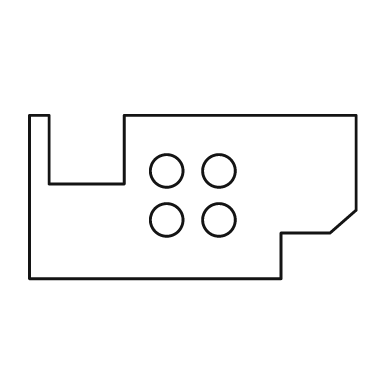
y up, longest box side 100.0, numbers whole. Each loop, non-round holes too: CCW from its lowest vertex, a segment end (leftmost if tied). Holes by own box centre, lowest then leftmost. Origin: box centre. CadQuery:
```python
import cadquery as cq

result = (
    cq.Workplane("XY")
    .moveTo(-50.0, -25.0)
    .lineTo(27.0, -25.0)
    .lineTo(27.0, -11.0)
    .lineTo(42.0, -11.0)
    .lineTo(50.0, -4.0)
    .lineTo(50.0, 25.0)
    .lineTo(-21.0, 25.0)
    .lineTo(-21.0, 4.0)
    .lineTo(-44.0, 4.0)
    .lineTo(-44.0, 25.0)
    .lineTo(-50.0, 25.0)
    .close()
    .moveTo(-8.0, -7.0)
    .circle(5.0)
    .moveTo(8.0, -7.0)
    .circle(5.0)
    .moveTo(-8.0, 8.0)
    .circle(5.0)
    .moveTo(8.0, 8.0)
    .circle(5.0)
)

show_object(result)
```